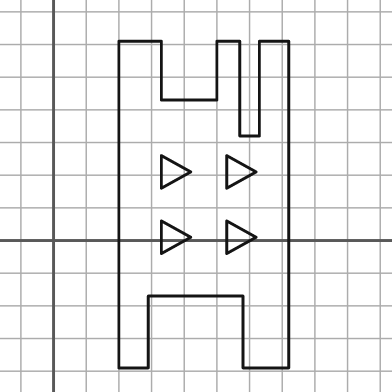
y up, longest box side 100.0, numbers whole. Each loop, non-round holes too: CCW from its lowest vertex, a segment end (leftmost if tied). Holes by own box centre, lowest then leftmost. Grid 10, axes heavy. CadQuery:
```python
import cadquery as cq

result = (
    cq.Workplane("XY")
    .moveTo(20.0, -39.0)
    .lineTo(29.0, -39.0)
    .lineTo(29.0, -17.0)
    .lineTo(58.0, -17.0)
    .lineTo(58.0, -39.0)
    .lineTo(72.0, -39.0)
    .lineTo(72.0, 61.0)
    .lineTo(63.0, 61.0)
    .lineTo(63.0, 32.0)
    .lineTo(57.0, 32.0)
    .lineTo(57.0, 61.0)
    .lineTo(50.0, 61.0)
    .lineTo(50.0, 43.0)
    .lineTo(33.0, 43.0)
    .lineTo(33.0, 61.0)
    .lineTo(20.0, 61.0)
    .close()
    .moveTo(33.0, -4.0)
    .lineTo(42.0, 1.0)
    .lineTo(33.0, 6.0)
    .close()
    .moveTo(53.0, -4.0)
    .lineTo(62.0, 1.0)
    .lineTo(53.0, 6.0)
    .close()
    .moveTo(33.0, 16.0)
    .lineTo(42.0, 21.0)
    .lineTo(33.0, 26.0)
    .close()
    .moveTo(53.0, 16.0)
    .lineTo(62.0, 21.0)
    .lineTo(53.0, 26.0)
    .close()
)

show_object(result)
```